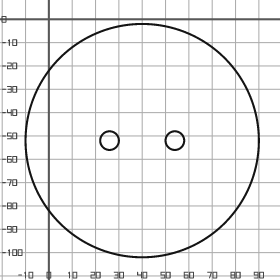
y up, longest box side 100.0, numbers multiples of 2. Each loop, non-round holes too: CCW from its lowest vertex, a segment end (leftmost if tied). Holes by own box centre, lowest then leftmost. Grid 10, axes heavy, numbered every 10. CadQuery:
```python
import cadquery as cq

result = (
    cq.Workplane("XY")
    .moveTo(40.0, -52.0)
    .circle(50.0)
    .moveTo(26.0, -52.0)
    .circle(4.0)
    .moveTo(54.0, -52.0)
    .circle(4.0)
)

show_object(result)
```